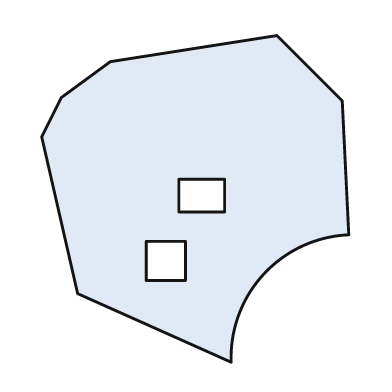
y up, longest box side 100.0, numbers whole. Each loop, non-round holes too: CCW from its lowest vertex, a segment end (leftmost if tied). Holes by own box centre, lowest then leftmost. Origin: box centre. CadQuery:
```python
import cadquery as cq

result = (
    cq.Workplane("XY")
    .moveTo(11.0, -50.0)
    .threePointArc((21.0, -23.0), (47.0, -11.0))
    .lineTo(45.0, 30.0)
    .lineTo(25.0, 50.0)
    .lineTo(-26.0, 42.0)
    .lineTo(-41.0, 31.0)
    .lineTo(-47.0, 19.0)
    .lineTo(-36.0, -29.0)
    .close()
    .moveTo(-15.0, -25.0)
    .lineTo(-3.0, -25.0)
    .lineTo(-3.0, -13.0)
    .lineTo(-15.0, -13.0)
    .close()
    .moveTo(-5.0, -4.0)
    .lineTo(9.0, -4.0)
    .lineTo(9.0, 6.0)
    .lineTo(-5.0, 6.0)
    .close()
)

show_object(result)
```